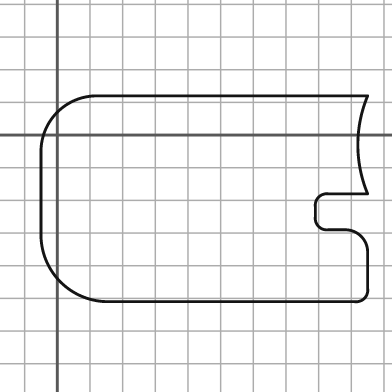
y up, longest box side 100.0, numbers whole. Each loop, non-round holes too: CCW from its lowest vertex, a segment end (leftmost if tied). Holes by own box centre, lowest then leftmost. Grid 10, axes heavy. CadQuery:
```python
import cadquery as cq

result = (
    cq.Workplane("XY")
    .moveTo(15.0, -51.0)
    .lineTo(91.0, -51.0)
    .threePointArc((94.0, -50.0), (95.0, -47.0))
    .lineTo(95.0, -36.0)
    .threePointArc((93.0, -31.0), (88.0, -29.0))
    .lineTo(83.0, -29.0)
    .threePointArc((80.0, -28.0), (79.0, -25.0))
    .lineTo(79.0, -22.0)
    .threePointArc((80.0, -19.0), (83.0, -18.0))
    .lineTo(95.0, -18.0)
    .threePointArc((92.0, -3.0), (95.0, 12.0))
    .lineTo(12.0, 12.0)
    .threePointArc((0.0, 7.0), (-5.0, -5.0))
    .lineTo(-5.0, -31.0)
    .threePointArc((1.0, -45.0), (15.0, -51.0))
    .close()
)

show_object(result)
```